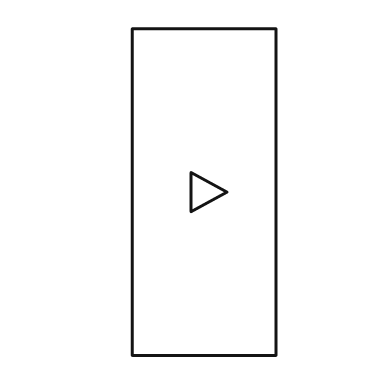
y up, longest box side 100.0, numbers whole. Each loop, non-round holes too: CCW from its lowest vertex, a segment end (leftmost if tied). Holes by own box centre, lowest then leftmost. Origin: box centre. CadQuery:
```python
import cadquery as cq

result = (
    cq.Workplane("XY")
    .moveTo(-22.0, -50.0)
    .lineTo(22.0, -50.0)
    .lineTo(22.0, 50.0)
    .lineTo(-22.0, 50.0)
    .close()
    .moveTo(-4.0, -6.0)
    .lineTo(7.0, 0.0)
    .lineTo(-4.0, 6.0)
    .close()
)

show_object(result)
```